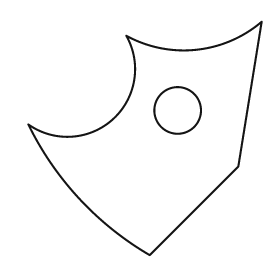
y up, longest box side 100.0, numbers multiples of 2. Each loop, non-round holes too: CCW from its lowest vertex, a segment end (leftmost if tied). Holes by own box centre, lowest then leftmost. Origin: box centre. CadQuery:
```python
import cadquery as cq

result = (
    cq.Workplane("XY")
    .moveTo(2.0, -50.0)
    .lineTo(40.0, -12.0)
    .lineTo(50.0, 50.0)
    .threePointArc((22.0, 38.0), (-8.0, 44.0))
    .threePointArc((-14.0, 8.0), (-50.0, 6.0))
    .threePointArc((-28.0, -26.0), (2.0, -50.0))
    .close()
    .moveTo(14.0, 12.0)
    .circle(10.0)
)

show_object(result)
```